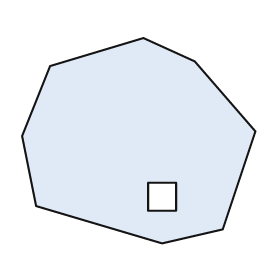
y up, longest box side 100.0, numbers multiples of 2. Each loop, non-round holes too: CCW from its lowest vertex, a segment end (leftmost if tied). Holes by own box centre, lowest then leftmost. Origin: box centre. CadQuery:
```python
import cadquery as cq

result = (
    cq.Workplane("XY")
    .moveTo(10.0, -44.0)
    .lineTo(36.0, -38.0)
    .lineTo(50.0, 4.0)
    .lineTo(24.0, 34.0)
    .lineTo(2.0, 44.0)
    .lineTo(-38.0, 32.0)
    .lineTo(-50.0, 2.0)
    .lineTo(-44.0, -28.0)
    .close()
    .moveTo(4.0, -30.0)
    .lineTo(16.0, -30.0)
    .lineTo(16.0, -18.0)
    .lineTo(4.0, -18.0)
    .close()
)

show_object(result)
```